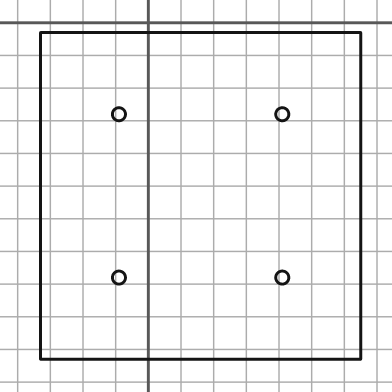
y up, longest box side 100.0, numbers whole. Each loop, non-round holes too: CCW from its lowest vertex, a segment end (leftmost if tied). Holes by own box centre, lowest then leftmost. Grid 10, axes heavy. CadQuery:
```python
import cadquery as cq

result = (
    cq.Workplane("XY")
    .moveTo(-33.0, -103.0)
    .lineTo(65.0, -103.0)
    .lineTo(65.0, -3.0)
    .lineTo(-33.0, -3.0)
    .close()
    .moveTo(-9.0, -78.0)
    .circle(2.0)
    .moveTo(41.0, -78.0)
    .circle(2.0)
    .moveTo(-9.0, -28.0)
    .circle(2.0)
    .moveTo(41.0, -28.0)
    .circle(2.0)
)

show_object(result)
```